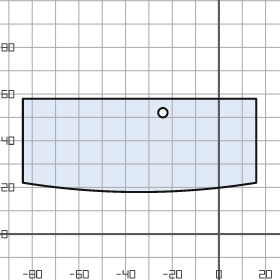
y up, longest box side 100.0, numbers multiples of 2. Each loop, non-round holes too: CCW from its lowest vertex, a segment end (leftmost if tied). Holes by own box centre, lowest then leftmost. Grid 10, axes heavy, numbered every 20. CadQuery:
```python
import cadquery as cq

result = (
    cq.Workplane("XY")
    .moveTo(-84.0, 22.0)
    .threePointArc((-34.0, 18.0), (16.0, 22.0))
    .lineTo(16.0, 58.0)
    .lineTo(-84.0, 58.0)
    .close()
    .moveTo(-24.0, 52.0)
    .circle(2.0)
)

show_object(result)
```